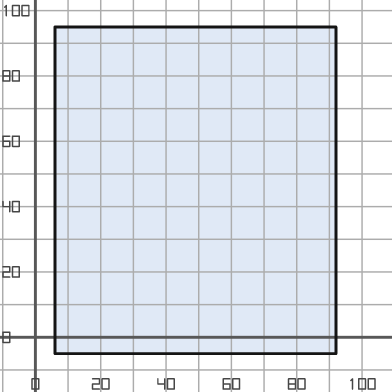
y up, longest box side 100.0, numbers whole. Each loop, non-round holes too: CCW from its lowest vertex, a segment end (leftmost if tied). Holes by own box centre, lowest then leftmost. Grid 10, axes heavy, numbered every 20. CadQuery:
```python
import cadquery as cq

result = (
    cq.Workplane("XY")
    .moveTo(6.0, -5.0)
    .lineTo(92.0, -5.0)
    .lineTo(92.0, 95.0)
    .lineTo(6.0, 95.0)
    .close()
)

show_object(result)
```